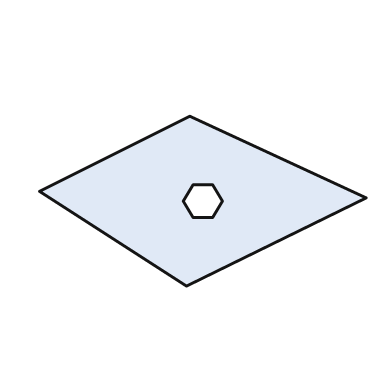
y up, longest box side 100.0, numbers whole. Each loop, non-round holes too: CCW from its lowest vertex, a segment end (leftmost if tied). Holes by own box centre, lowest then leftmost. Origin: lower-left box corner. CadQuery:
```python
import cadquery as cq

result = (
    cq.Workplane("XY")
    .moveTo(45.0, 0.0)
    .lineTo(100.0, 27.0)
    .lineTo(46.0, 52.0)
    .lineTo(0.0, 29.0)
    .close()
    .moveTo(47.0, 21.0)
    .lineTo(53.0, 21.0)
    .lineTo(56.0, 26.0)
    .lineTo(53.0, 31.0)
    .lineTo(47.0, 31.0)
    .lineTo(44.0, 26.0)
    .close()
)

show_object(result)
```